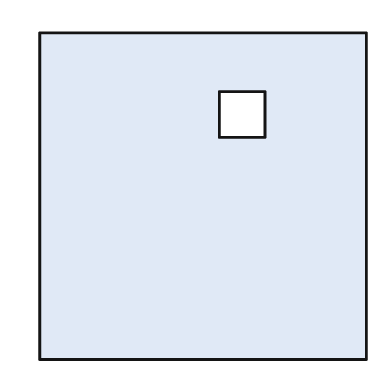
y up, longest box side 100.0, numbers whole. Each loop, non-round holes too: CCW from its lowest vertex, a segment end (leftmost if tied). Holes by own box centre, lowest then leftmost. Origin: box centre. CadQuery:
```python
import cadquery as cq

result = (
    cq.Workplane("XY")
    .moveTo(-50.0, -50.0)
    .lineTo(50.0, -50.0)
    .lineTo(50.0, 50.0)
    .lineTo(-50.0, 50.0)
    .close()
    .moveTo(5.0, 18.0)
    .lineTo(19.0, 18.0)
    .lineTo(19.0, 32.0)
    .lineTo(5.0, 32.0)
    .close()
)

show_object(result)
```